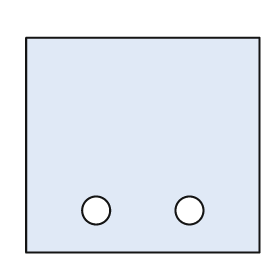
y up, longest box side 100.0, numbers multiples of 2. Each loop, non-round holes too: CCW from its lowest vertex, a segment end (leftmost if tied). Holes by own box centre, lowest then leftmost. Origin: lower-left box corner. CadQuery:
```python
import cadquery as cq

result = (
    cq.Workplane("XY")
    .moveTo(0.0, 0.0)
    .lineTo(100.0, 0.0)
    .lineTo(100.0, 92.0)
    .lineTo(0.0, 92.0)
    .close()
    .moveTo(30.0, 18.0)
    .circle(6.0)
    .moveTo(70.0, 18.0)
    .circle(6.0)
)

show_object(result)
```